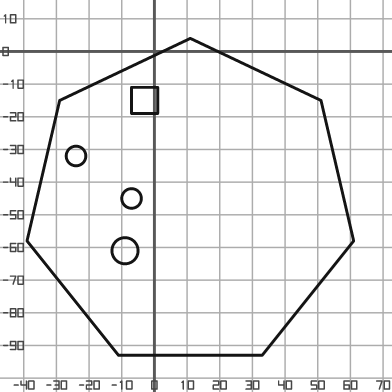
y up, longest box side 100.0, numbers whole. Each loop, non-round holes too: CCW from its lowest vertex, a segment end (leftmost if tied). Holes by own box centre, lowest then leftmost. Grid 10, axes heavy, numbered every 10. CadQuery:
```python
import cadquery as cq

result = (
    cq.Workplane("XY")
    .moveTo(-11.0, -93.0)
    .lineTo(33.0, -93.0)
    .lineTo(61.0, -58.0)
    .lineTo(51.0, -15.0)
    .lineTo(11.0, 4.0)
    .lineTo(-29.0, -15.0)
    .lineTo(-39.0, -58.0)
    .close()
    .moveTo(-9.0, -61.0)
    .circle(4.0)
    .moveTo(-7.0, -45.0)
    .circle(3.0)
    .moveTo(-24.0, -32.0)
    .circle(3.0)
    .moveTo(-7.0, -19.0)
    .lineTo(1.0, -19.0)
    .lineTo(1.0, -11.0)
    .lineTo(-7.0, -11.0)
    .close()
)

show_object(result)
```